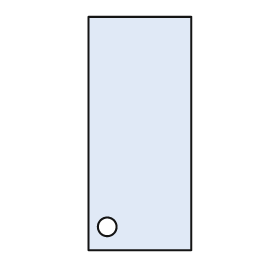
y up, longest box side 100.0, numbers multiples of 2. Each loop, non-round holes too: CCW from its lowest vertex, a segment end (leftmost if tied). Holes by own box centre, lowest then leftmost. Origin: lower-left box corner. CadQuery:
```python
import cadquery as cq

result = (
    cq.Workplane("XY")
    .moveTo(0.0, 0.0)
    .lineTo(44.0, 0.0)
    .lineTo(44.0, 100.0)
    .lineTo(0.0, 100.0)
    .close()
    .moveTo(8.0, 10.0)
    .circle(4.0)
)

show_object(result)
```